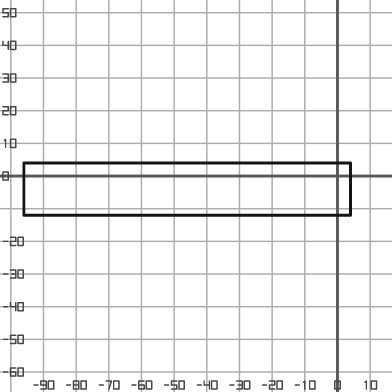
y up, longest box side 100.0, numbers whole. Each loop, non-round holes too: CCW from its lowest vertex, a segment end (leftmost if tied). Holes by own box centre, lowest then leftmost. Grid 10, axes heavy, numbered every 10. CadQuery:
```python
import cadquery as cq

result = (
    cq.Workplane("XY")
    .moveTo(-96.0, -12.0)
    .lineTo(4.0, -12.0)
    .lineTo(4.0, 4.0)
    .lineTo(-96.0, 4.0)
    .close()
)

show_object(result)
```